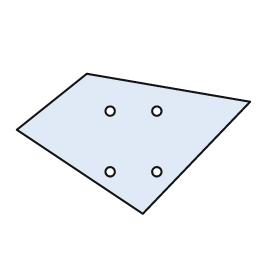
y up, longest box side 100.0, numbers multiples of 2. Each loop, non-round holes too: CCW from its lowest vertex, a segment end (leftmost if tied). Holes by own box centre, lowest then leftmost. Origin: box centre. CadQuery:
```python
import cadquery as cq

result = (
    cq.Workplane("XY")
    .moveTo(4.0, -30.0)
    .lineTo(50.0, 18.0)
    .lineTo(-20.0, 30.0)
    .lineTo(-50.0, 6.0)
    .close()
    .moveTo(-10.0, -12.0)
    .circle(2.0)
    .moveTo(10.0, -12.0)
    .circle(2.0)
    .moveTo(-10.0, 14.0)
    .circle(2.0)
    .moveTo(10.0, 14.0)
    .circle(2.0)
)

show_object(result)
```